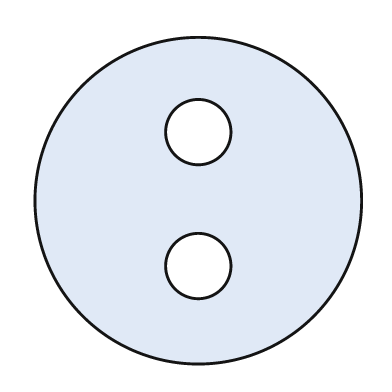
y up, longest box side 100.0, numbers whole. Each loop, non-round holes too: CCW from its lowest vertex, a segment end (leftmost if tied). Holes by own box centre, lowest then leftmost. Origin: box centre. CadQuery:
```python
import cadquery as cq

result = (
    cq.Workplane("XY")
    .moveTo(0.0, 0.0)
    .circle(50.0)
    .moveTo(0.0, -20.0)
    .circle(10.0)
    .moveTo(0.0, 21.0)
    .circle(10.0)
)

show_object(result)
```